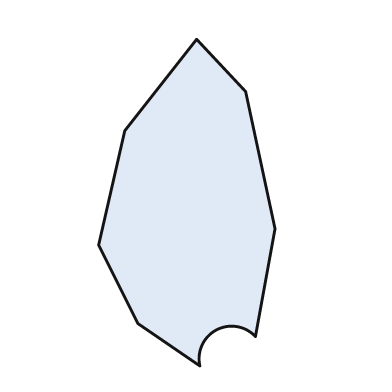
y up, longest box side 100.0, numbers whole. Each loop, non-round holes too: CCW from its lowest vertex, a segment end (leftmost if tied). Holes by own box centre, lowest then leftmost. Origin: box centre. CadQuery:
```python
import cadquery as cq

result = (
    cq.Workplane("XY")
    .moveTo(4.0, -50.0)
    .threePointArc((9.0, -39.0), (21.0, -41.0))
    .lineTo(27.0, -8.0)
    .lineTo(18.0, 34.0)
    .lineTo(3.0, 50.0)
    .lineTo(-19.0, 22.0)
    .lineTo(-27.0, -13.0)
    .lineTo(-15.0, -37.0)
    .close()
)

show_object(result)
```